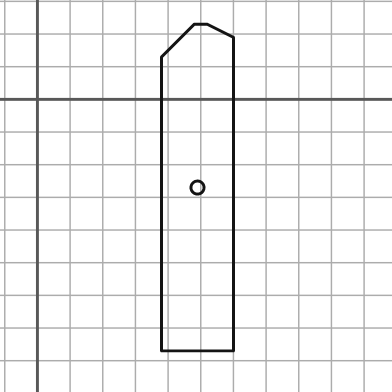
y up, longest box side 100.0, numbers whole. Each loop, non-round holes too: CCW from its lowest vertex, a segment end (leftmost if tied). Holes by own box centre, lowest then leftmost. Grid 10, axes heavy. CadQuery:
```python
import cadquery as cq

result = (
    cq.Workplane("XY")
    .moveTo(38.0, -77.0)
    .lineTo(60.0, -77.0)
    .lineTo(60.0, 19.0)
    .lineTo(52.0, 23.0)
    .lineTo(48.0, 23.0)
    .lineTo(38.0, 13.0)
    .close()
    .moveTo(49.0, -27.0)
    .circle(2.0)
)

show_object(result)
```